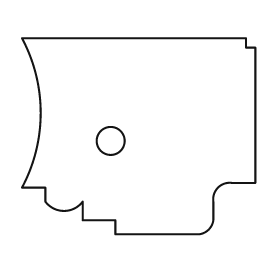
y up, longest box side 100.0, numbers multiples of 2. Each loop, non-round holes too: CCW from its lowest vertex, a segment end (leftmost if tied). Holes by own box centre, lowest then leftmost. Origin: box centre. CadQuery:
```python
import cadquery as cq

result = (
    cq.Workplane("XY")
    .moveTo(-10.0, -42.0)
    .lineTo(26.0, -42.0)
    .threePointArc((30.0, -40.0), (32.0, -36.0))
    .lineTo(32.0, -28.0)
    .threePointArc((34.0, -22.0), (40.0, -20.0))
    .lineTo(50.0, -20.0)
    .lineTo(50.0, 38.0)
    .lineTo(46.0, 38.0)
    .lineTo(46.0, 42.0)
    .lineTo(-50.0, 42.0)
    .threePointArc((-42.0, 10.0), (-50.0, -22.0))
    .lineTo(-40.0, -22.0)
    .lineTo(-40.0, -28.0)
    .threePointArc((-32.0, -32.0), (-24.0, -28.0))
    .lineTo(-24.0, -36.0)
    .lineTo(-10.0, -36.0)
    .close()
    .moveTo(-12.0, -2.0)
    .circle(6.0)
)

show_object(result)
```